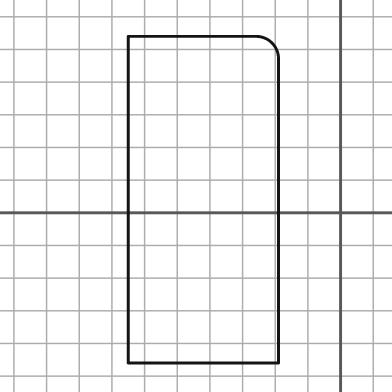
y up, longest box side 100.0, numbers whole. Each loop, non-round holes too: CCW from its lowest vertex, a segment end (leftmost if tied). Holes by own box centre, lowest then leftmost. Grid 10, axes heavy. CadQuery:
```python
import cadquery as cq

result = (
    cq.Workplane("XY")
    .moveTo(-65.0, -46.0)
    .lineTo(-19.0, -46.0)
    .lineTo(-19.0, 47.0)
    .threePointArc((-21.0, 52.0), (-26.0, 54.0))
    .lineTo(-65.0, 54.0)
    .close()
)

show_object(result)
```